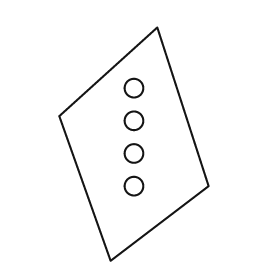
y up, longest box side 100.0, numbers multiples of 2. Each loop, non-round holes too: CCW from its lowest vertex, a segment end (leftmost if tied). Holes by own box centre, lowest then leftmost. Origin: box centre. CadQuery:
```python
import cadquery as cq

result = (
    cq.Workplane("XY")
    .moveTo(-10.0, -50.0)
    .lineTo(32.0, -18.0)
    .lineTo(10.0, 50.0)
    .lineTo(-32.0, 12.0)
    .close()
    .moveTo(0.0, -18.0)
    .circle(4.0)
    .moveTo(0.0, -4.0)
    .circle(4.0)
    .moveTo(0.0, 10.0)
    .circle(4.0)
    .moveTo(0.0, 24.0)
    .circle(4.0)
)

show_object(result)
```